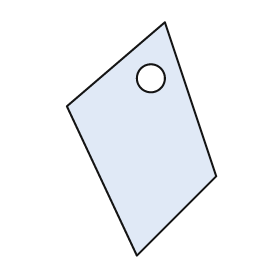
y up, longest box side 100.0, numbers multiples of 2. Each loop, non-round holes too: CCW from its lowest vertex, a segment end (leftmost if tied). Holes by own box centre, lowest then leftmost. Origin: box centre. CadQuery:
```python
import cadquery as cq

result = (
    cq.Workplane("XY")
    .moveTo(-2.0, -50.0)
    .lineTo(32.0, -16.0)
    .lineTo(10.0, 50.0)
    .lineTo(-32.0, 14.0)
    .close()
    .moveTo(4.0, 26.0)
    .circle(6.0)
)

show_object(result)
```